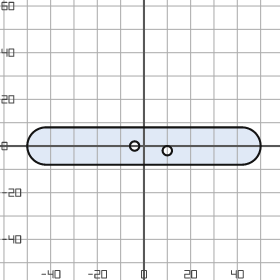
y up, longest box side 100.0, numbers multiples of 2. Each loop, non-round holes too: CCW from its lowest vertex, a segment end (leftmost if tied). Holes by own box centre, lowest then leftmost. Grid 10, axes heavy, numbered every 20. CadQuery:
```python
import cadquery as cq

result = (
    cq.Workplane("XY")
    .moveTo(-42.0, -8.0)
    .lineTo(42.0, -8.0)
    .threePointArc((50.0, 0.0), (42.0, 8.0))
    .lineTo(-42.0, 8.0)
    .threePointArc((-50.0, 0.0), (-42.0, -8.0))
    .close()
    .moveTo(10.0, -2.0)
    .circle(2.0)
    .moveTo(-4.0, 0.0)
    .circle(2.0)
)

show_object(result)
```